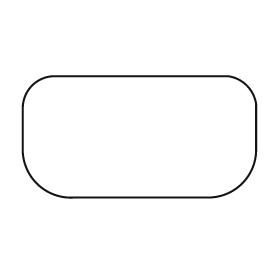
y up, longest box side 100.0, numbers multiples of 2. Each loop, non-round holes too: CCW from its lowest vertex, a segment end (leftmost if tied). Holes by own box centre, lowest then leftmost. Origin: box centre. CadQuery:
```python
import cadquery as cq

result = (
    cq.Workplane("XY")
    .moveTo(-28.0, -26.0)
    .lineTo(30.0, -26.0)
    .threePointArc((44.0, -20.0), (50.0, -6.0))
    .lineTo(50.0, 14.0)
    .threePointArc((46.0, 22.0), (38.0, 26.0))
    .lineTo(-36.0, 26.0)
    .threePointArc((-46.0, 22.0), (-50.0, 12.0))
    .lineTo(-50.0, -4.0)
    .threePointArc((-44.0, -20.0), (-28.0, -26.0))
    .close()
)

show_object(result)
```